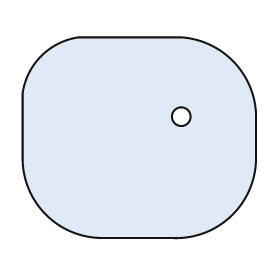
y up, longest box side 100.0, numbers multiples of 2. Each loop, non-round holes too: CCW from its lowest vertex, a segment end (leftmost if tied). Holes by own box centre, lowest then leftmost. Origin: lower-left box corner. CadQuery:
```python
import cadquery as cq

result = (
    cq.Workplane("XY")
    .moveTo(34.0, 0.0)
    .lineTo(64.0, 0.0)
    .threePointArc((90.0, 10.0), (100.0, 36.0))
    .lineTo(100.0, 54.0)
    .threePointArc((90.0, 76.0), (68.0, 86.0))
    .lineTo(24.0, 86.0)
    .threePointArc((8.0, 78.0), (0.0, 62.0))
    .lineTo(0.0, 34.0)
    .threePointArc((10.0, 10.0), (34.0, 0.0))
    .close()
    .moveTo(68.0, 52.0)
    .circle(4.0)
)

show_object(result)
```